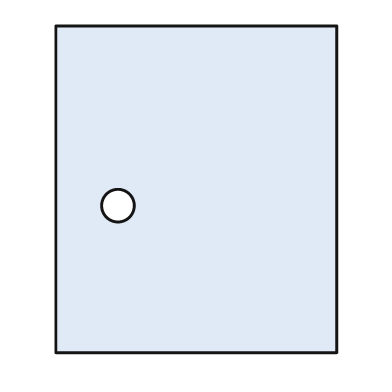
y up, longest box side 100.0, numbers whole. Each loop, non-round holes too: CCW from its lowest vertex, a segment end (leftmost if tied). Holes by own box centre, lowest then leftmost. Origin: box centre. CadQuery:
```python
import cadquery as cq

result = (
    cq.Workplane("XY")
    .moveTo(-43.0, -50.0)
    .lineTo(43.0, -50.0)
    .lineTo(43.0, 50.0)
    .lineTo(-43.0, 50.0)
    .close()
    .moveTo(-24.0, -5.0)
    .circle(5.0)
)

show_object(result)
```